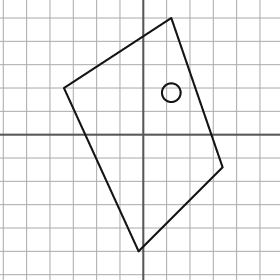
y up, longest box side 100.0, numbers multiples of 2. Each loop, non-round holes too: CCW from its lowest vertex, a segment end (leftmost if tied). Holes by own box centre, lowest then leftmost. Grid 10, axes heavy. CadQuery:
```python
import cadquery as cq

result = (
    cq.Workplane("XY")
    .moveTo(-2.0, -50.0)
    .lineTo(34.0, -14.0)
    .lineTo(12.0, 50.0)
    .lineTo(-34.0, 20.0)
    .close()
    .moveTo(12.0, 18.0)
    .circle(4.0)
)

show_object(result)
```